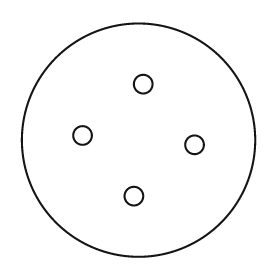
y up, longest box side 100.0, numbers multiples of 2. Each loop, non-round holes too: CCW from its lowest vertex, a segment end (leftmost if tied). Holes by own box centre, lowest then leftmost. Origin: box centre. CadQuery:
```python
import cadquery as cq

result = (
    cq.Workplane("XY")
    .moveTo(0.0, 0.0)
    .circle(50.0)
    .moveTo(-2.0, -24.0)
    .circle(4.0)
    .moveTo(24.0, -2.0)
    .circle(4.0)
    .moveTo(-24.0, 2.0)
    .circle(4.0)
    .moveTo(2.0, 24.0)
    .circle(4.0)
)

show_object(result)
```